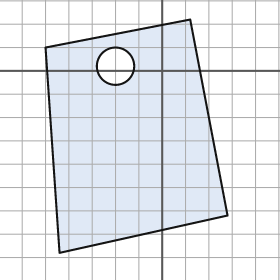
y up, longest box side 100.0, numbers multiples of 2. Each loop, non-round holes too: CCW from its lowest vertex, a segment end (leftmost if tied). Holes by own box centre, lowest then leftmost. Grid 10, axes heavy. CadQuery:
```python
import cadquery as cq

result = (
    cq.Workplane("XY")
    .moveTo(-44.0, -78.0)
    .lineTo(28.0, -62.0)
    .lineTo(12.0, 22.0)
    .lineTo(-50.0, 10.0)
    .close()
    .moveTo(-20.0, 2.0)
    .circle(8.0)
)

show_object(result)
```